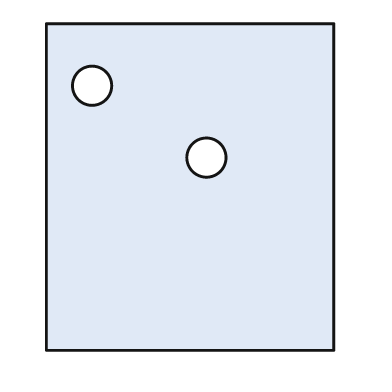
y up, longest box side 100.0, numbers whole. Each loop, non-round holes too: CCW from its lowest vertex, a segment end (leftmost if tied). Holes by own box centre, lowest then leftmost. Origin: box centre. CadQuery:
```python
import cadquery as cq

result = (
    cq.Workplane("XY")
    .moveTo(-44.0, -50.0)
    .lineTo(44.0, -50.0)
    .lineTo(44.0, 50.0)
    .lineTo(-44.0, 50.0)
    .close()
    .moveTo(5.0, 9.0)
    .circle(6.0)
    .moveTo(-30.0, 31.0)
    .circle(6.0)
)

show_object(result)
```